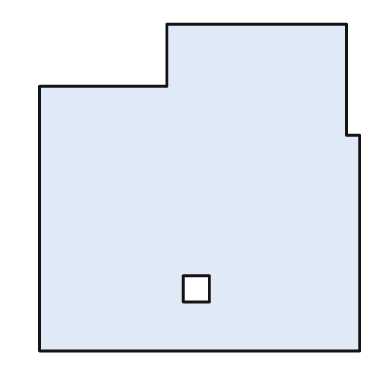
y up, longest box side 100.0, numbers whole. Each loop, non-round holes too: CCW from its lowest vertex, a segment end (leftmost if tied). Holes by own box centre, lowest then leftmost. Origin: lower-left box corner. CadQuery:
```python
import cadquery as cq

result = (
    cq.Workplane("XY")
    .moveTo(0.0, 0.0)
    .lineTo(98.0, 0.0)
    .lineTo(98.0, 66.0)
    .lineTo(94.0, 66.0)
    .lineTo(94.0, 100.0)
    .lineTo(39.0, 100.0)
    .lineTo(39.0, 81.0)
    .lineTo(0.0, 81.0)
    .close()
    .moveTo(44.0, 15.0)
    .lineTo(52.0, 15.0)
    .lineTo(52.0, 23.0)
    .lineTo(44.0, 23.0)
    .close()
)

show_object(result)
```